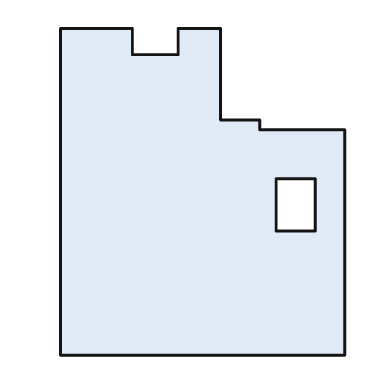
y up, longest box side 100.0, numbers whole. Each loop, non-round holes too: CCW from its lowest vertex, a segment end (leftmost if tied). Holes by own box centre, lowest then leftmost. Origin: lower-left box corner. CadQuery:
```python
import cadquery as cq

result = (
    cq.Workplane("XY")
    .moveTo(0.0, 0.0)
    .lineTo(87.0, 0.0)
    .lineTo(87.0, 69.0)
    .lineTo(61.0, 69.0)
    .lineTo(61.0, 72.0)
    .lineTo(49.0, 72.0)
    .lineTo(49.0, 100.0)
    .lineTo(36.0, 100.0)
    .lineTo(36.0, 92.0)
    .lineTo(22.0, 92.0)
    .lineTo(22.0, 100.0)
    .lineTo(0.0, 100.0)
    .close()
    .moveTo(66.0, 38.0)
    .lineTo(78.0, 38.0)
    .lineTo(78.0, 54.0)
    .lineTo(66.0, 54.0)
    .close()
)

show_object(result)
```